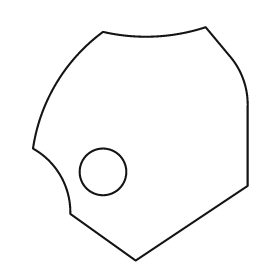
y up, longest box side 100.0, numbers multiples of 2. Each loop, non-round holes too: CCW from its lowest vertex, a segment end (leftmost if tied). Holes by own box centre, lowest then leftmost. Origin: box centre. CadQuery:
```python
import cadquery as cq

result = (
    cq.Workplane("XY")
    .moveTo(-2.0, -50.0)
    .lineTo(46.0, -18.0)
    .lineTo(46.0, 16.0)
    .threePointArc((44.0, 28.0), (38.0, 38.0))
    .lineTo(28.0, 50.0)
    .threePointArc((6.0, 46.0), (-16.0, 48.0))
    .threePointArc((-36.0, 26.0), (-46.0, -2.0))
    .threePointArc((-34.0, -14.0), (-30.0, -30.0))
    .close()
    .moveTo(-16.0, -12.0)
    .circle(10.0)
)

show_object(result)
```